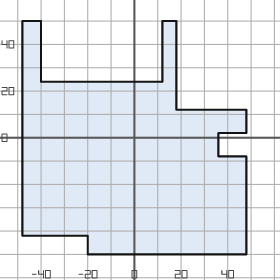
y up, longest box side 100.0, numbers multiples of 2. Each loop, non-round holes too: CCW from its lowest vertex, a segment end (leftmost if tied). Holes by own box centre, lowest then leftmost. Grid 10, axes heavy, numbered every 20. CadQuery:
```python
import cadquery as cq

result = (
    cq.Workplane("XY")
    .moveTo(-20.0, -50.0)
    .lineTo(48.0, -50.0)
    .lineTo(48.0, -8.0)
    .lineTo(36.0, -8.0)
    .lineTo(36.0, 2.0)
    .lineTo(48.0, 2.0)
    .lineTo(48.0, 12.0)
    .lineTo(18.0, 12.0)
    .lineTo(18.0, 50.0)
    .lineTo(12.0, 50.0)
    .lineTo(12.0, 24.0)
    .lineTo(-40.0, 24.0)
    .lineTo(-40.0, 50.0)
    .lineTo(-48.0, 50.0)
    .lineTo(-48.0, -42.0)
    .lineTo(-20.0, -42.0)
    .close()
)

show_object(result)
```